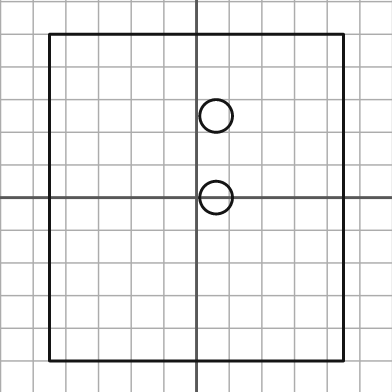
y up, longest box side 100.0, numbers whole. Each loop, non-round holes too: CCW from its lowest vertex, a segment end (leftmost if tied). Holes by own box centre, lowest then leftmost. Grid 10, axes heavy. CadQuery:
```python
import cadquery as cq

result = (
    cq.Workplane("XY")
    .moveTo(-45.0, -50.0)
    .lineTo(45.0, -50.0)
    .lineTo(45.0, 50.0)
    .lineTo(-45.0, 50.0)
    .close()
    .moveTo(6.0, 0.0)
    .circle(5.0)
    .moveTo(6.0, 25.0)
    .circle(5.0)
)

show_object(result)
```